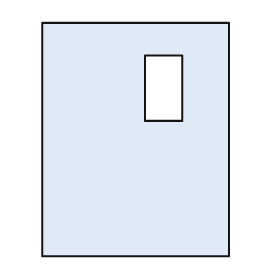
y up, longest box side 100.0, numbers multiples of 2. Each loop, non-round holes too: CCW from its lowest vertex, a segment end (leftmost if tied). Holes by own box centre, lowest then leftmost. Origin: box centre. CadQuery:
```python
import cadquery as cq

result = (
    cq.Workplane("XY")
    .moveTo(-40.0, -50.0)
    .lineTo(40.0, -50.0)
    .lineTo(40.0, 50.0)
    .lineTo(-40.0, 50.0)
    .close()
    .moveTo(4.0, 8.0)
    .lineTo(20.0, 8.0)
    .lineTo(20.0, 36.0)
    .lineTo(4.0, 36.0)
    .close()
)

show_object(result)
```